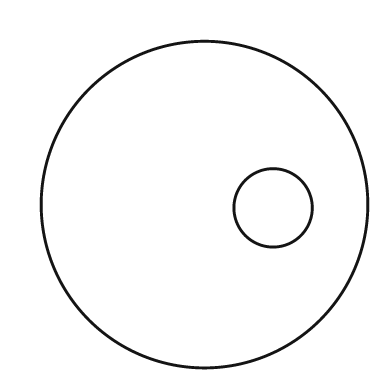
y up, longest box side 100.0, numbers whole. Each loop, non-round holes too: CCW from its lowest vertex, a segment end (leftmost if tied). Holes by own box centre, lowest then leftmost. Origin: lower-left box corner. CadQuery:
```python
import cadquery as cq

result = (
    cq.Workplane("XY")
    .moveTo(50.0, 50.0)
    .circle(50.0)
    .moveTo(71.0, 49.0)
    .circle(12.0)
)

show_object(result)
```